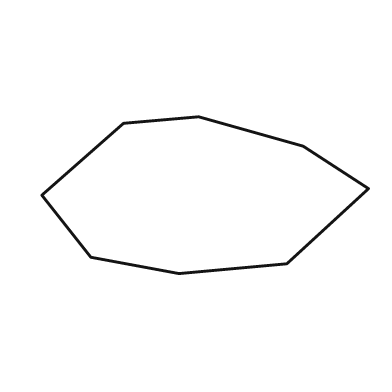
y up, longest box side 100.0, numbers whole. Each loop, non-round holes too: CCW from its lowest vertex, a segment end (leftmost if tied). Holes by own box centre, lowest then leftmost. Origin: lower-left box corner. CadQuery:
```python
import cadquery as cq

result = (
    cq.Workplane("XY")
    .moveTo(42.0, 0.0)
    .lineTo(75.0, 3.0)
    .lineTo(100.0, 26.0)
    .lineTo(80.0, 39.0)
    .lineTo(48.0, 48.0)
    .lineTo(25.0, 46.0)
    .lineTo(0.0, 24.0)
    .lineTo(15.0, 5.0)
    .close()
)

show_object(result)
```